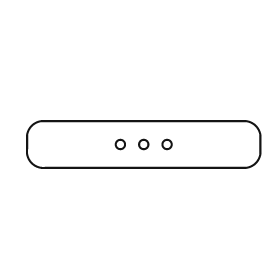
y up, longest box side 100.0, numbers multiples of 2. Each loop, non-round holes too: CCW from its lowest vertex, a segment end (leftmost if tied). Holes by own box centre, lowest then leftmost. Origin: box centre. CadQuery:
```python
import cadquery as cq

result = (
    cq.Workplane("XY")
    .moveTo(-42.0, -10.0)
    .lineTo(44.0, -10.0)
    .threePointArc((48.0, -8.0), (50.0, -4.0))
    .lineTo(50.0, 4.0)
    .threePointArc((48.0, 8.0), (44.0, 10.0))
    .lineTo(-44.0, 10.0)
    .threePointArc((-48.0, 8.0), (-50.0, 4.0))
    .lineTo(-50.0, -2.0)
    .threePointArc((-48.0, -8.0), (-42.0, -10.0))
    .close()
    .moveTo(-10.0, 0.0)
    .circle(2.0)
    .moveTo(0.0, 0.0)
    .circle(2.0)
    .moveTo(10.0, 0.0)
    .circle(2.0)
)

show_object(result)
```